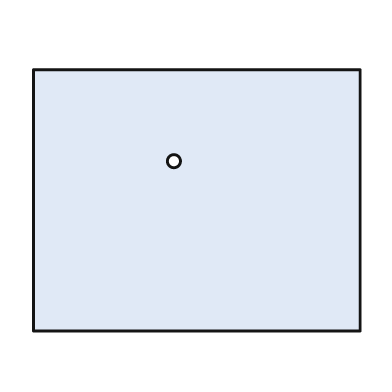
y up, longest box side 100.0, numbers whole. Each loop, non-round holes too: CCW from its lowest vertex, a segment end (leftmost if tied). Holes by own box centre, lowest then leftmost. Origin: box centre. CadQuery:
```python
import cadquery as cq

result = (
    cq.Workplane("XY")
    .moveTo(-50.0, -40.0)
    .lineTo(50.0, -40.0)
    .lineTo(50.0, 40.0)
    .lineTo(-50.0, 40.0)
    .close()
    .moveTo(-7.0, 12.0)
    .circle(2.0)
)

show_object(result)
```